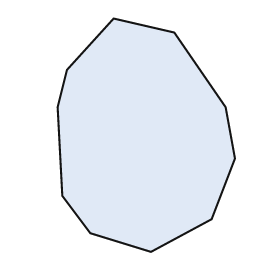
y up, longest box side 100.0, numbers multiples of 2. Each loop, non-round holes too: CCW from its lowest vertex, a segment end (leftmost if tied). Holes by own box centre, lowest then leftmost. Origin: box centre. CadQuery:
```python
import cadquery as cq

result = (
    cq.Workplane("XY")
    .moveTo(2.0, -50.0)
    .lineTo(28.0, -36.0)
    .lineTo(38.0, -10.0)
    .lineTo(34.0, 12.0)
    .lineTo(12.0, 44.0)
    .lineTo(-14.0, 50.0)
    .lineTo(-34.0, 28.0)
    .lineTo(-38.0, 12.0)
    .lineTo(-36.0, -26.0)
    .lineTo(-24.0, -42.0)
    .close()
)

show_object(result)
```